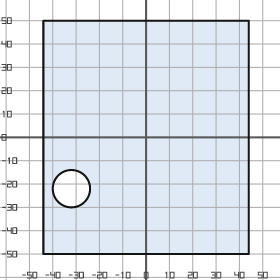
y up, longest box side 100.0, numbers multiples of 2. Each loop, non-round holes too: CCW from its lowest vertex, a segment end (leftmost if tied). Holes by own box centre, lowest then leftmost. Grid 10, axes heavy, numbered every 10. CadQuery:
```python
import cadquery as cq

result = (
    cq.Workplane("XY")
    .moveTo(-44.0, -50.0)
    .lineTo(44.0, -50.0)
    .lineTo(44.0, 50.0)
    .lineTo(-44.0, 50.0)
    .close()
    .moveTo(-32.0, -22.0)
    .circle(8.0)
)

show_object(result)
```